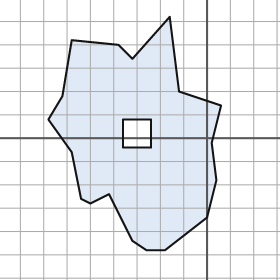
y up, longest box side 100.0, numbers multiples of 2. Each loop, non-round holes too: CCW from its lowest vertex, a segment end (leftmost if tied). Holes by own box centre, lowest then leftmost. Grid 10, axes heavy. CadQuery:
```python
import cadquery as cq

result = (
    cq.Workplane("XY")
    .moveTo(-26.0, -48.0)
    .lineTo(-18.0, -48.0)
    .lineTo(0.0, -34.0)
    .lineTo(4.0, -18.0)
    .lineTo(2.0, -2.0)
    .lineTo(6.0, 14.0)
    .lineTo(-12.0, 20.0)
    .lineTo(-16.0, 52.0)
    .lineTo(-32.0, 34.0)
    .lineTo(-38.0, 40.0)
    .lineTo(-58.0, 42.0)
    .lineTo(-62.0, 18.0)
    .lineTo(-68.0, 8.0)
    .lineTo(-58.0, -6.0)
    .lineTo(-54.0, -26.0)
    .lineTo(-50.0, -28.0)
    .lineTo(-42.0, -24.0)
    .lineTo(-32.0, -44.0)
    .close()
    .moveTo(-36.0, -4.0)
    .lineTo(-24.0, -4.0)
    .lineTo(-24.0, 8.0)
    .lineTo(-36.0, 8.0)
    .close()
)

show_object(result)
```